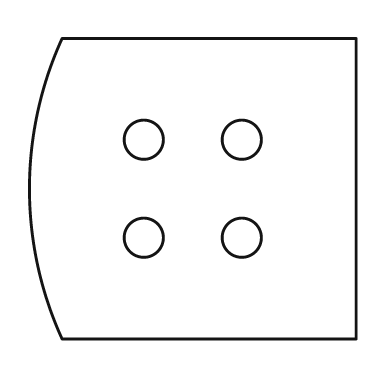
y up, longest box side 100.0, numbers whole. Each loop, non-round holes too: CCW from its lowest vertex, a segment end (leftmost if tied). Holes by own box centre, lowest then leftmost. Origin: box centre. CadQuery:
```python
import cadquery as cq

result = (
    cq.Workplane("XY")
    .moveTo(-40.0, -46.0)
    .lineTo(50.0, -46.0)
    .lineTo(50.0, 46.0)
    .lineTo(-40.0, 46.0)
    .threePointArc((-50.0, 0.0), (-40.0, -46.0))
    .close()
    .moveTo(-15.0, -15.0)
    .circle(6.0)
    .moveTo(15.0, -15.0)
    .circle(6.0)
    .moveTo(-15.0, 15.0)
    .circle(6.0)
    .moveTo(15.0, 15.0)
    .circle(6.0)
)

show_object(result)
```